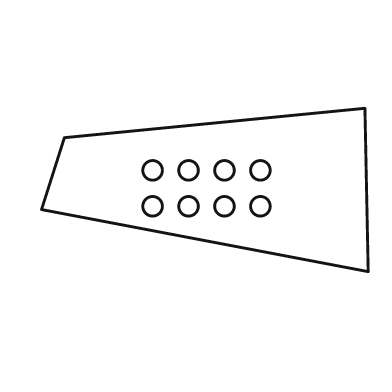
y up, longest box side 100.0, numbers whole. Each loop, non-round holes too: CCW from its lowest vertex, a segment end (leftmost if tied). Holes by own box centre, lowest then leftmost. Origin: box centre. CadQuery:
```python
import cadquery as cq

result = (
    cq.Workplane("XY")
    .moveTo(50.0, -25.0)
    .lineTo(49.0, 25.0)
    .lineTo(-43.0, 16.0)
    .lineTo(-50.0, -6.0)
    .close()
    .moveTo(-16.0, -5.0)
    .circle(3.0)
    .moveTo(-5.0, -5.0)
    .circle(3.0)
    .moveTo(6.0, -5.0)
    .circle(3.0)
    .moveTo(17.0, -5.0)
    .circle(3.0)
    .moveTo(-16.0, 6.0)
    .circle(3.0)
    .moveTo(-5.0, 6.0)
    .circle(3.0)
    .moveTo(6.0, 6.0)
    .circle(3.0)
    .moveTo(17.0, 6.0)
    .circle(3.0)
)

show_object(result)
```